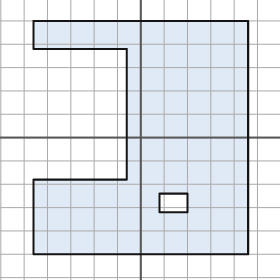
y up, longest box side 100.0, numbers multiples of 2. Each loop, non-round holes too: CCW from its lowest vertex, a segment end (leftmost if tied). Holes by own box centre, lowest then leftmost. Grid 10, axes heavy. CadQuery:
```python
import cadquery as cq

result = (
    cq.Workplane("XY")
    .moveTo(-46.0, -50.0)
    .lineTo(46.0, -50.0)
    .lineTo(46.0, 50.0)
    .lineTo(-46.0, 50.0)
    .lineTo(-46.0, 38.0)
    .lineTo(-6.0, 38.0)
    .lineTo(-6.0, -18.0)
    .lineTo(-46.0, -18.0)
    .close()
    .moveTo(8.0, -32.0)
    .lineTo(20.0, -32.0)
    .lineTo(20.0, -24.0)
    .lineTo(8.0, -24.0)
    .close()
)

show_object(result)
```